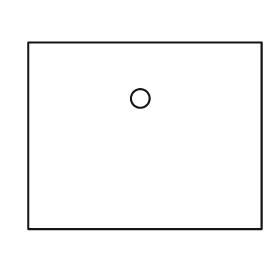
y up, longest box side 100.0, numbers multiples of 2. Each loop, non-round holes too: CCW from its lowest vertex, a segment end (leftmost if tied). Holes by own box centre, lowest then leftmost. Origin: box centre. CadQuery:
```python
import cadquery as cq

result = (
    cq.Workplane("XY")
    .moveTo(-50.0, -40.0)
    .lineTo(50.0, -40.0)
    .lineTo(50.0, 40.0)
    .lineTo(-50.0, 40.0)
    .close()
    .moveTo(-2.0, 16.0)
    .circle(4.0)
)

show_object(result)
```